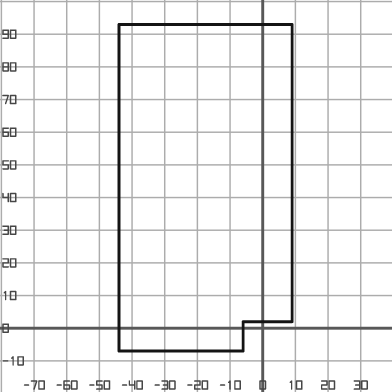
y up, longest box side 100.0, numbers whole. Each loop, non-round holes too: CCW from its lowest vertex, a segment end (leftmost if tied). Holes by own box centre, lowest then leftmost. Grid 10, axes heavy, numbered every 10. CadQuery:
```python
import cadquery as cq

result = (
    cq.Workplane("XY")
    .moveTo(-44.0, -7.0)
    .lineTo(-6.0, -7.0)
    .lineTo(-6.0, 2.0)
    .lineTo(9.0, 2.0)
    .lineTo(9.0, 93.0)
    .lineTo(-44.0, 93.0)
    .close()
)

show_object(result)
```